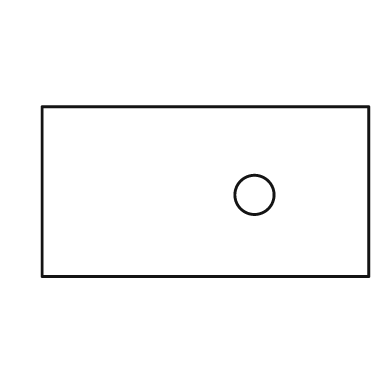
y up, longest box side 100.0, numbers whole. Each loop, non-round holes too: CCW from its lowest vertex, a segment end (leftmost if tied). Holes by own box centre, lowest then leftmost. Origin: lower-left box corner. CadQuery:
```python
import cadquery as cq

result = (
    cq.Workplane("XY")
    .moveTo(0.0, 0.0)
    .lineTo(100.0, 0.0)
    .lineTo(100.0, 52.0)
    .lineTo(0.0, 52.0)
    .close()
    .moveTo(65.0, 25.0)
    .circle(6.0)
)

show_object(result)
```